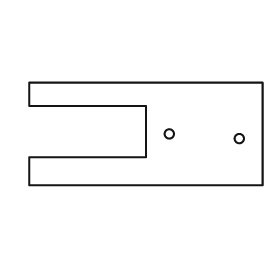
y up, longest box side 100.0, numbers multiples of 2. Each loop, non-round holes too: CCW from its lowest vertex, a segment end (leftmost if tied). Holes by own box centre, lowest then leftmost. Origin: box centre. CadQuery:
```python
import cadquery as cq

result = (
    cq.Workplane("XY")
    .moveTo(-50.0, -22.0)
    .lineTo(50.0, -22.0)
    .lineTo(50.0, 22.0)
    .lineTo(-50.0, 22.0)
    .lineTo(-50.0, 12.0)
    .lineTo(0.0, 12.0)
    .lineTo(0.0, -10.0)
    .lineTo(-50.0, -10.0)
    .close()
    .moveTo(40.0, -2.0)
    .circle(2.0)
    .moveTo(10.0, 0.0)
    .circle(2.0)
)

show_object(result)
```